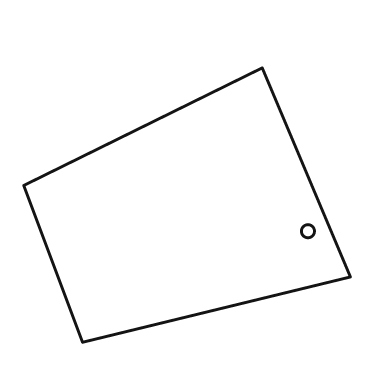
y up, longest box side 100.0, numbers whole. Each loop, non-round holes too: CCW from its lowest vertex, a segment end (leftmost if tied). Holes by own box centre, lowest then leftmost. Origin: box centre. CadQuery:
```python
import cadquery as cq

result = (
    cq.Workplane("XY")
    .moveTo(-32.0, -42.0)
    .lineTo(50.0, -22.0)
    .lineTo(23.0, 42.0)
    .lineTo(-50.0, 6.0)
    .close()
    .moveTo(37.0, -8.0)
    .circle(2.0)
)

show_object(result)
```